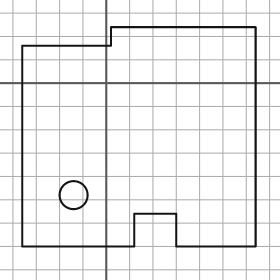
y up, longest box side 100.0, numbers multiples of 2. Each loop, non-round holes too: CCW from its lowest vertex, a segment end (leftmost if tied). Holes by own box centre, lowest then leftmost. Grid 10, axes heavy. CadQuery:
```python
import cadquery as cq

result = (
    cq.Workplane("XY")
    .moveTo(-36.0, -70.0)
    .lineTo(12.0, -70.0)
    .lineTo(12.0, -56.0)
    .lineTo(30.0, -56.0)
    .lineTo(30.0, -70.0)
    .lineTo(64.0, -70.0)
    .lineTo(64.0, 24.0)
    .lineTo(2.0, 24.0)
    .lineTo(2.0, 16.0)
    .lineTo(-36.0, 16.0)
    .close()
    .moveTo(-14.0, -48.0)
    .circle(6.0)
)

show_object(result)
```